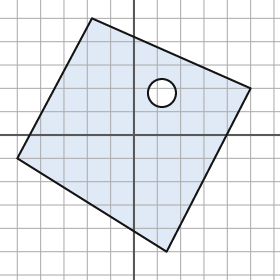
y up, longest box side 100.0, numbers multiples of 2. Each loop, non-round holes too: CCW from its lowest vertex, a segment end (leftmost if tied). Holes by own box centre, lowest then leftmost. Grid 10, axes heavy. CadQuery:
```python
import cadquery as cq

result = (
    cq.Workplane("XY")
    .moveTo(14.0, -50.0)
    .lineTo(50.0, 20.0)
    .lineTo(-18.0, 50.0)
    .lineTo(-50.0, -10.0)
    .close()
    .moveTo(12.0, 18.0)
    .circle(6.0)
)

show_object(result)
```